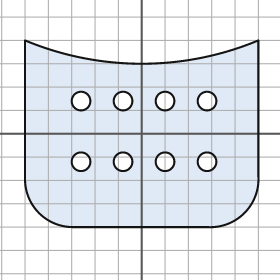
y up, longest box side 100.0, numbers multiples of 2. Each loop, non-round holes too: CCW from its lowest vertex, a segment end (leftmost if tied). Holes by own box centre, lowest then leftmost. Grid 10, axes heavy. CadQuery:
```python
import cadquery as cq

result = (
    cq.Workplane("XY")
    .moveTo(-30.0, -40.0)
    .lineTo(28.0, -40.0)
    .threePointArc((44.0, -34.0), (50.0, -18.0))
    .lineTo(50.0, 40.0)
    .threePointArc((0.0, 30.0), (-50.0, 40.0))
    .lineTo(-50.0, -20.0)
    .threePointArc((-44.0, -34.0), (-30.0, -40.0))
    .close()
    .moveTo(-26.0, -12.0)
    .circle(4.0)
    .moveTo(-8.0, -12.0)
    .circle(4.0)
    .moveTo(10.0, -12.0)
    .circle(4.0)
    .moveTo(28.0, -12.0)
    .circle(4.0)
    .moveTo(-26.0, 14.0)
    .circle(4.0)
    .moveTo(-8.0, 14.0)
    .circle(4.0)
    .moveTo(10.0, 14.0)
    .circle(4.0)
    .moveTo(28.0, 14.0)
    .circle(4.0)
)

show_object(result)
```